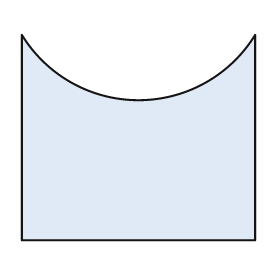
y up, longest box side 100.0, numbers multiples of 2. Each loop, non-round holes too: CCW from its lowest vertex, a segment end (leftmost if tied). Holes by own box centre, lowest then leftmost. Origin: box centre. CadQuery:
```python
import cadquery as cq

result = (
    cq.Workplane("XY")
    .moveTo(-50.0, -44.0)
    .lineTo(50.0, -44.0)
    .lineTo(50.0, 44.0)
    .threePointArc((0.0, 16.0), (-50.0, 44.0))
    .close()
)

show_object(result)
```